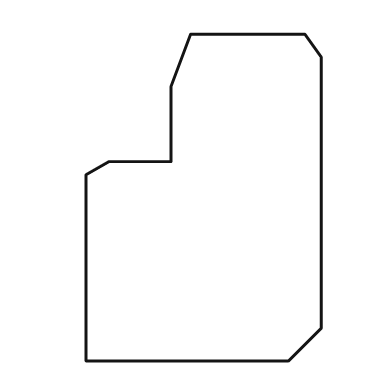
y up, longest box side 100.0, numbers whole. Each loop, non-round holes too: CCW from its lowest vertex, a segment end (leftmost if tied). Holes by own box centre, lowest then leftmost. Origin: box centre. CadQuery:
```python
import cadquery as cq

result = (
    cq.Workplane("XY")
    .moveTo(-36.0, -50.0)
    .lineTo(26.0, -50.0)
    .lineTo(36.0, -40.0)
    .lineTo(36.0, 43.0)
    .lineTo(31.0, 50.0)
    .lineTo(-4.0, 50.0)
    .lineTo(-10.0, 34.0)
    .lineTo(-10.0, 11.0)
    .lineTo(-29.0, 11.0)
    .lineTo(-36.0, 7.0)
    .close()
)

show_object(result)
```